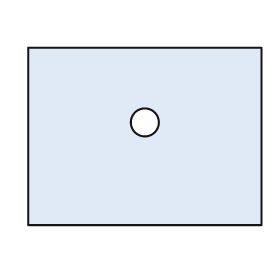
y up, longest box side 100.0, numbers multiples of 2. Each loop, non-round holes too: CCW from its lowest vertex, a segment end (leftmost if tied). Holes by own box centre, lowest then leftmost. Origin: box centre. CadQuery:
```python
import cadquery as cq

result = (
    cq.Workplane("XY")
    .moveTo(-50.0, -38.0)
    .lineTo(50.0, -38.0)
    .lineTo(50.0, 38.0)
    .lineTo(-50.0, 38.0)
    .close()
    .moveTo(0.0, 6.0)
    .circle(6.0)
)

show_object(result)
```